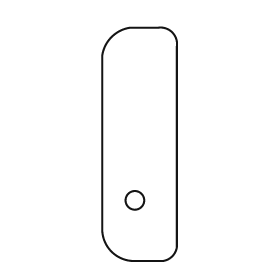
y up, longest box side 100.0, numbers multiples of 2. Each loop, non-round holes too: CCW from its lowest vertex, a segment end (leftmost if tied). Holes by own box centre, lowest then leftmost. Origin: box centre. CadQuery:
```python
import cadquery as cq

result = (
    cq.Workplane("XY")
    .moveTo(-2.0, -50.0)
    .lineTo(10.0, -50.0)
    .threePointArc((14.0, -48.0), (16.0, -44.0))
    .lineTo(16.0, 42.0)
    .threePointArc((14.0, 48.0), (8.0, 50.0))
    .lineTo(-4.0, 50.0)
    .threePointArc((-12.0, 46.0), (-16.0, 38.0))
    .lineTo(-16.0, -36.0)
    .threePointArc((-12.0, -46.0), (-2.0, -50.0))
    .close()
    .moveTo(-2.0, -24.0)
    .circle(4.0)
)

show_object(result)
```